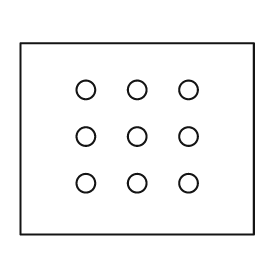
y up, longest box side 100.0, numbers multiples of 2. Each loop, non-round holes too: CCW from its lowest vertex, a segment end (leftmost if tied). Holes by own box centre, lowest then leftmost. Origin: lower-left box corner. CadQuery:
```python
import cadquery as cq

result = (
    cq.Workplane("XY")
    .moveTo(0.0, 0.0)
    .lineTo(100.0, 0.0)
    .lineTo(100.0, 82.0)
    .lineTo(0.0, 82.0)
    .close()
    .moveTo(28.0, 22.0)
    .circle(4.0)
    .moveTo(50.0, 22.0)
    .circle(4.0)
    .moveTo(72.0, 22.0)
    .circle(4.0)
    .moveTo(28.0, 42.0)
    .circle(4.0)
    .moveTo(50.0, 42.0)
    .circle(4.0)
    .moveTo(72.0, 42.0)
    .circle(4.0)
    .moveTo(28.0, 62.0)
    .circle(4.0)
    .moveTo(50.0, 62.0)
    .circle(4.0)
    .moveTo(72.0, 62.0)
    .circle(4.0)
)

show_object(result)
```